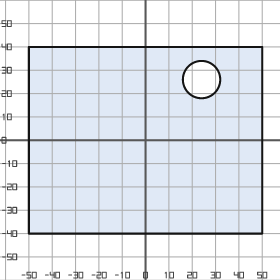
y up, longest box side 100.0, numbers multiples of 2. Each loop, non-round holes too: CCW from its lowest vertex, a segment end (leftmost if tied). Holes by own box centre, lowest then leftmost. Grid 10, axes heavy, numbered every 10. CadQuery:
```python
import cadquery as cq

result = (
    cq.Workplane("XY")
    .moveTo(-50.0, -40.0)
    .lineTo(50.0, -40.0)
    .lineTo(50.0, 40.0)
    .lineTo(-50.0, 40.0)
    .close()
    .moveTo(24.0, 26.0)
    .circle(8.0)
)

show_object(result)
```